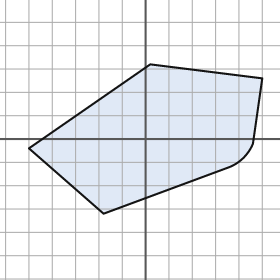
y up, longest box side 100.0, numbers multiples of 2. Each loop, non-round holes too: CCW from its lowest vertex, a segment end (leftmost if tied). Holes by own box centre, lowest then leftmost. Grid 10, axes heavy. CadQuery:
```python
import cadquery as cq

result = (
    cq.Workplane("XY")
    .moveTo(-18.0, -32.0)
    .lineTo(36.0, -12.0)
    .threePointArc((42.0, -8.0), (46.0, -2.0))
    .lineTo(50.0, 26.0)
    .lineTo(2.0, 32.0)
    .lineTo(-50.0, -4.0)
    .close()
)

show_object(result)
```